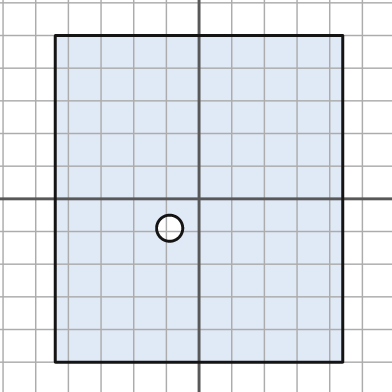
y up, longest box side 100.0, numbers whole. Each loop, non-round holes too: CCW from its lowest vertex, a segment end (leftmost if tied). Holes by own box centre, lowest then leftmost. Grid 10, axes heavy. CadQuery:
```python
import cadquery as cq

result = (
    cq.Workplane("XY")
    .moveTo(-44.0, -50.0)
    .lineTo(44.0, -50.0)
    .lineTo(44.0, 50.0)
    .lineTo(-44.0, 50.0)
    .close()
    .moveTo(-9.0, -9.0)
    .circle(4.0)
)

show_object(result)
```